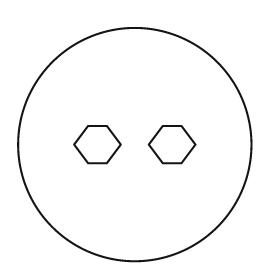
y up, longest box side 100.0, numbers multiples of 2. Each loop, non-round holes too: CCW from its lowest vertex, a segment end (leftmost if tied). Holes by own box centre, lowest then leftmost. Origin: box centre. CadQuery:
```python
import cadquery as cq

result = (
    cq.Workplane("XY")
    .moveTo(0.0, 0.0)
    .circle(50.0)
    .moveTo(-20.0, -8.0)
    .lineTo(-12.0, -8.0)
    .lineTo(-6.0, 0.0)
    .lineTo(-12.0, 8.0)
    .lineTo(-20.0, 8.0)
    .lineTo(-26.0, 0.0)
    .close()
    .moveTo(12.0, -8.0)
    .lineTo(20.0, -8.0)
    .lineTo(26.0, 0.0)
    .lineTo(20.0, 8.0)
    .lineTo(12.0, 8.0)
    .lineTo(6.0, 0.0)
    .close()
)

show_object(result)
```